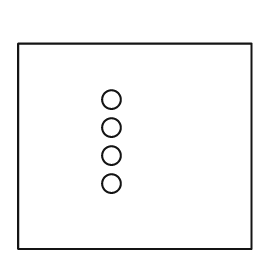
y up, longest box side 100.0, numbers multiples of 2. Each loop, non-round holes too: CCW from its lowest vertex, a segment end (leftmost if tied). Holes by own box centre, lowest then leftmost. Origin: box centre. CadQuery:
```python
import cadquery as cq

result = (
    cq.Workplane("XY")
    .moveTo(-50.0, -44.0)
    .lineTo(50.0, -44.0)
    .lineTo(50.0, 44.0)
    .lineTo(-50.0, 44.0)
    .close()
    .moveTo(-10.0, -16.0)
    .circle(4.0)
    .moveTo(-10.0, -4.0)
    .circle(4.0)
    .moveTo(-10.0, 8.0)
    .circle(4.0)
    .moveTo(-10.0, 20.0)
    .circle(4.0)
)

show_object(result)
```